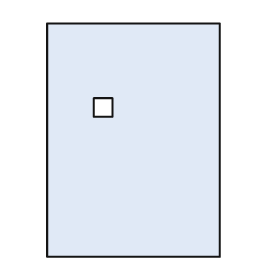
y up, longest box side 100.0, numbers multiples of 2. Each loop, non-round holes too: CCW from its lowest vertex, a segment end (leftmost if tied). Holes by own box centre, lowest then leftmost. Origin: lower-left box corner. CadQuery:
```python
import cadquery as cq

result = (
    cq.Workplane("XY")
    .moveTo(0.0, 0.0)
    .lineTo(74.0, 0.0)
    .lineTo(74.0, 100.0)
    .lineTo(0.0, 100.0)
    .close()
    .moveTo(20.0, 60.0)
    .lineTo(28.0, 60.0)
    .lineTo(28.0, 68.0)
    .lineTo(20.0, 68.0)
    .close()
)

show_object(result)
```